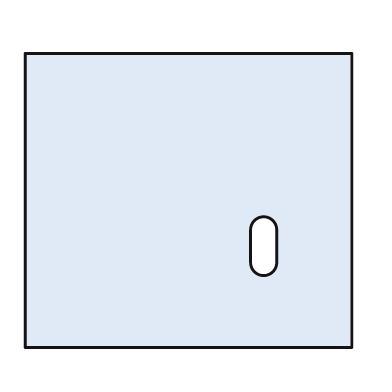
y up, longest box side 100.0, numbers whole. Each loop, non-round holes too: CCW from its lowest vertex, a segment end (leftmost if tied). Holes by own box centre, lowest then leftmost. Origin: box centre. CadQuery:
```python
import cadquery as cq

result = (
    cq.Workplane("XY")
    .moveTo(-50.0, -45.0)
    .lineTo(50.0, -45.0)
    .lineTo(50.0, 45.0)
    .lineTo(-50.0, 45.0)
    .close()
    .moveTo(19.0, -19.0)
    .threePointArc((23.0, -23.0), (27.0, -19.0))
    .lineTo(27.0, -9.0)
    .threePointArc((23.0, -5.0), (19.0, -9.0))
    .close()
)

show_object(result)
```